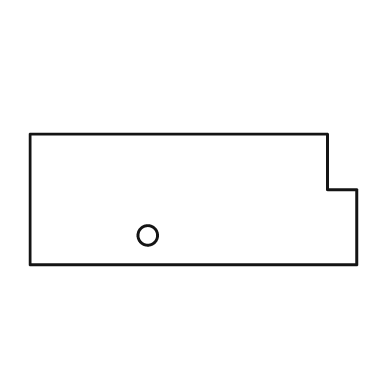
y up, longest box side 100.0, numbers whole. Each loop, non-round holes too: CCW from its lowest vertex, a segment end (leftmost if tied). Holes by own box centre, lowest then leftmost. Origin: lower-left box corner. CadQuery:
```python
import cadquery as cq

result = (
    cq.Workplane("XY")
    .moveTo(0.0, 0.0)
    .lineTo(100.0, 0.0)
    .lineTo(100.0, 23.0)
    .lineTo(91.0, 23.0)
    .lineTo(91.0, 40.0)
    .lineTo(0.0, 40.0)
    .close()
    .moveTo(36.0, 9.0)
    .circle(3.0)
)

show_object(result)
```